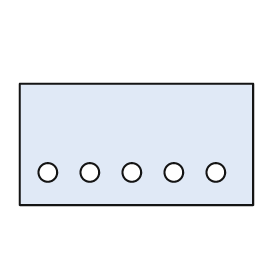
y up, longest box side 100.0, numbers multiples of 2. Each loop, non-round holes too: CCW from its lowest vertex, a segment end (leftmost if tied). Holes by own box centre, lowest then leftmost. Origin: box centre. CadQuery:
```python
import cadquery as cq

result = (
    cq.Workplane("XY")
    .moveTo(-50.0, -26.0)
    .lineTo(50.0, -26.0)
    .lineTo(50.0, 26.0)
    .lineTo(-50.0, 26.0)
    .close()
    .moveTo(-38.0, -12.0)
    .circle(4.0)
    .moveTo(-20.0, -12.0)
    .circle(4.0)
    .moveTo(-2.0, -12.0)
    .circle(4.0)
    .moveTo(16.0, -12.0)
    .circle(4.0)
    .moveTo(34.0, -12.0)
    .circle(4.0)
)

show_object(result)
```